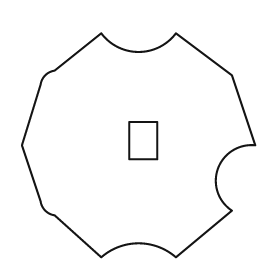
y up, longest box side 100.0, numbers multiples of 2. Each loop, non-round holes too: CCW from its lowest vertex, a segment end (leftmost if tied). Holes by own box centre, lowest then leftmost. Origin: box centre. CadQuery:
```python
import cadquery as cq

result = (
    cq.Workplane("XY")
    .moveTo(-16.0, -48.0)
    .threePointArc((0.0, -42.0), (16.0, -48.0))
    .lineTo(40.0, -28.0)
    .threePointArc((34.0, -10.0), (50.0, 0.0))
    .lineTo(40.0, 30.0)
    .lineTo(16.0, 48.0)
    .threePointArc((0.0, 40.0), (-16.0, 48.0))
    .lineTo(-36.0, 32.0)
    .threePointArc((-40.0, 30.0), (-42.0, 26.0))
    .lineTo(-50.0, 0.0)
    .lineTo(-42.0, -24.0)
    .threePointArc((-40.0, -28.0), (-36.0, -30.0))
    .close()
    .moveTo(-4.0, -6.0)
    .lineTo(8.0, -6.0)
    .lineTo(8.0, 10.0)
    .lineTo(-4.0, 10.0)
    .close()
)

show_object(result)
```